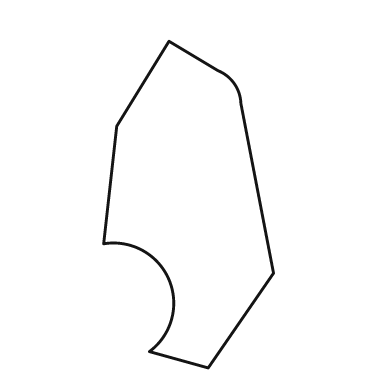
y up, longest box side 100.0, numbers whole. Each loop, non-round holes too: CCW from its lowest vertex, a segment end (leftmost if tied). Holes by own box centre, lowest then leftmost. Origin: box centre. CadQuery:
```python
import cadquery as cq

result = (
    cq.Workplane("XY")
    .moveTo(6.0, -50.0)
    .lineTo(26.0, -21.0)
    .lineTo(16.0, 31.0)
    .threePointArc((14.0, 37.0), (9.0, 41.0))
    .lineTo(-6.0, 50.0)
    .lineTo(-22.0, 24.0)
    .lineTo(-26.0, -12.0)
    .threePointArc((-6.0, -23.0), (-12.0, -45.0))
    .close()
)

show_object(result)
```